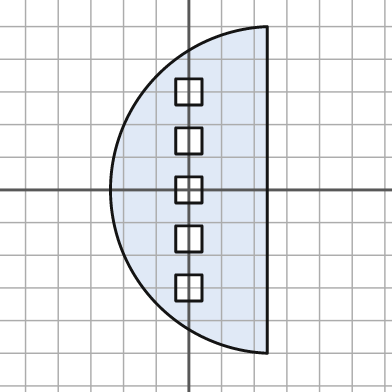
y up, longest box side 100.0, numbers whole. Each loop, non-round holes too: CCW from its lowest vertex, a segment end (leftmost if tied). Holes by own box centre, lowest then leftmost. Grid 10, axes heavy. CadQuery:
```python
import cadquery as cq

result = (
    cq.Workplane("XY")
    .moveTo(24.0, -50.0)
    .lineTo(24.0, 50.0)
    .threePointArc((-24.0, 0.0), (24.0, -50.0))
    .close()
    .moveTo(-4.0, -34.0)
    .lineTo(4.0, -34.0)
    .lineTo(4.0, -26.0)
    .lineTo(-4.0, -26.0)
    .close()
    .moveTo(-4.0, -19.0)
    .lineTo(4.0, -19.0)
    .lineTo(4.0, -11.0)
    .lineTo(-4.0, -11.0)
    .close()
    .moveTo(-4.0, -4.0)
    .lineTo(4.0, -4.0)
    .lineTo(4.0, 4.0)
    .lineTo(-4.0, 4.0)
    .close()
    .moveTo(-4.0, 11.0)
    .lineTo(4.0, 11.0)
    .lineTo(4.0, 19.0)
    .lineTo(-4.0, 19.0)
    .close()
    .moveTo(-4.0, 26.0)
    .lineTo(4.0, 26.0)
    .lineTo(4.0, 34.0)
    .lineTo(-4.0, 34.0)
    .close()
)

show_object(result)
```